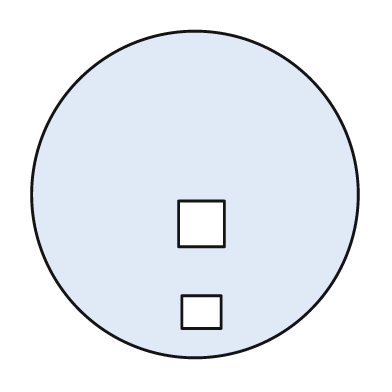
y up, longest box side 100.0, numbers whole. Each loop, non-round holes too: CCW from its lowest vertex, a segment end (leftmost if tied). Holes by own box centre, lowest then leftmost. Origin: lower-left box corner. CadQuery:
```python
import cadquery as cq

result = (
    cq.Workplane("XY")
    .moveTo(50.0, 50.0)
    .circle(50.0)
    .moveTo(46.0, 9.0)
    .lineTo(58.0, 9.0)
    .lineTo(58.0, 19.0)
    .lineTo(46.0, 19.0)
    .close()
    .moveTo(45.0, 34.0)
    .lineTo(59.0, 34.0)
    .lineTo(59.0, 48.0)
    .lineTo(45.0, 48.0)
    .close()
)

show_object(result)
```